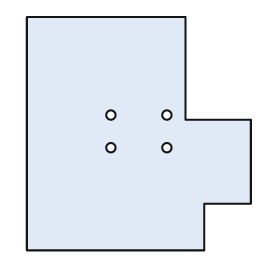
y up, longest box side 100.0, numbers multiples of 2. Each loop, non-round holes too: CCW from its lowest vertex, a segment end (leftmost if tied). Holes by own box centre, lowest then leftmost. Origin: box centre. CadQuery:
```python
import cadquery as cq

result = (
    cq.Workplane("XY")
    .moveTo(-48.0, -50.0)
    .lineTo(28.0, -50.0)
    .lineTo(28.0, -30.0)
    .lineTo(48.0, -30.0)
    .lineTo(48.0, 6.0)
    .lineTo(20.0, 6.0)
    .lineTo(20.0, 50.0)
    .lineTo(-48.0, 50.0)
    .close()
    .moveTo(-12.0, -6.0)
    .circle(2.0)
    .moveTo(12.0, -6.0)
    .circle(2.0)
    .moveTo(-12.0, 8.0)
    .circle(2.0)
    .moveTo(12.0, 8.0)
    .circle(2.0)
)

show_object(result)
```